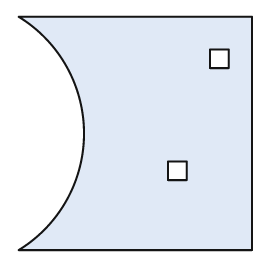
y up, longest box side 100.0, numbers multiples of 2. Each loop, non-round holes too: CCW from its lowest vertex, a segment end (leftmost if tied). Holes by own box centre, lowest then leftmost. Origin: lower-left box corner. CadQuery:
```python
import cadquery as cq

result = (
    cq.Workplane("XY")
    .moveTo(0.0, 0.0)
    .lineTo(100.0, 0.0)
    .lineTo(100.0, 100.0)
    .lineTo(0.0, 100.0)
    .threePointArc((28.0, 50.0), (0.0, 0.0))
    .close()
    .moveTo(64.0, 30.0)
    .lineTo(72.0, 30.0)
    .lineTo(72.0, 38.0)
    .lineTo(64.0, 38.0)
    .close()
    .moveTo(82.0, 78.0)
    .lineTo(90.0, 78.0)
    .lineTo(90.0, 86.0)
    .lineTo(82.0, 86.0)
    .close()
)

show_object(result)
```